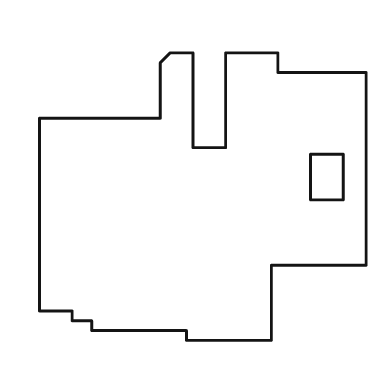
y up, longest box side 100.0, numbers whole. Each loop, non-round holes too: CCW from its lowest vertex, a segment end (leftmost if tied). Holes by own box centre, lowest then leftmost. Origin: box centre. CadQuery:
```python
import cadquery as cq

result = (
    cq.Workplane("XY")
    .moveTo(-5.0, -44.0)
    .lineTo(21.0, -44.0)
    .lineTo(21.0, -21.0)
    .lineTo(50.0, -21.0)
    .lineTo(50.0, 38.0)
    .lineTo(23.0, 38.0)
    .lineTo(23.0, 44.0)
    .lineTo(7.0, 44.0)
    .lineTo(7.0, 15.0)
    .lineTo(-3.0, 15.0)
    .lineTo(-3.0, 44.0)
    .lineTo(-10.0, 44.0)
    .lineTo(-13.0, 41.0)
    .lineTo(-13.0, 24.0)
    .lineTo(-50.0, 24.0)
    .lineTo(-50.0, -35.0)
    .lineTo(-40.0, -35.0)
    .lineTo(-40.0, -38.0)
    .lineTo(-34.0, -38.0)
    .lineTo(-34.0, -41.0)
    .lineTo(-5.0, -41.0)
    .close()
    .moveTo(33.0, -1.0)
    .lineTo(43.0, -1.0)
    .lineTo(43.0, 13.0)
    .lineTo(33.0, 13.0)
    .close()
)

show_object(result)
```